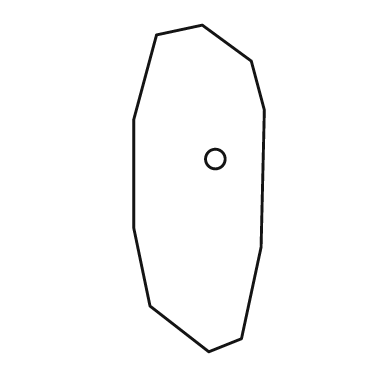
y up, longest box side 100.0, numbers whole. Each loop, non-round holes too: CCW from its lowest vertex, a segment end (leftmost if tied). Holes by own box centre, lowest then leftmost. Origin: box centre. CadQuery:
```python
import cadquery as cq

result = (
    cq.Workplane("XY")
    .moveTo(3.0, -50.0)
    .lineTo(13.0, -46.0)
    .lineTo(19.0, -18.0)
    .lineTo(20.0, 24.0)
    .lineTo(16.0, 39.0)
    .lineTo(1.0, 50.0)
    .lineTo(-13.0, 47.0)
    .lineTo(-20.0, 21.0)
    .lineTo(-20.0, -12.0)
    .lineTo(-15.0, -36.0)
    .close()
    .moveTo(5.0, 9.0)
    .circle(3.0)
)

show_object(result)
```